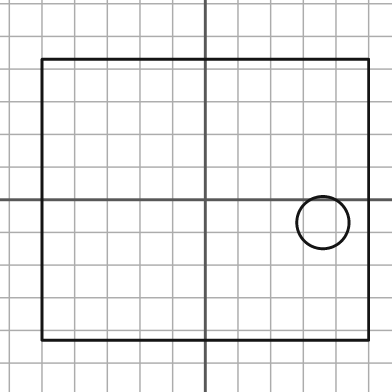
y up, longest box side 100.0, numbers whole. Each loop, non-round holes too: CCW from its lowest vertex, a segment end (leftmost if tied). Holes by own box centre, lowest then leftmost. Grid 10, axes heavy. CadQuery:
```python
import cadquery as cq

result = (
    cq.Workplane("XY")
    .moveTo(-50.0, -43.0)
    .lineTo(50.0, -43.0)
    .lineTo(50.0, 43.0)
    .lineTo(-50.0, 43.0)
    .close()
    .moveTo(36.0, -7.0)
    .circle(8.0)
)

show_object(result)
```